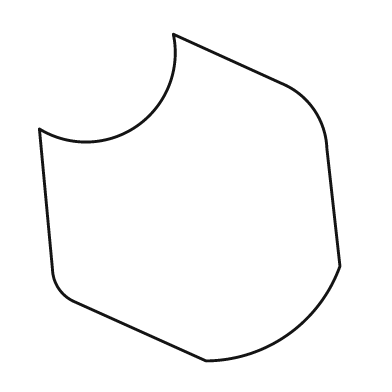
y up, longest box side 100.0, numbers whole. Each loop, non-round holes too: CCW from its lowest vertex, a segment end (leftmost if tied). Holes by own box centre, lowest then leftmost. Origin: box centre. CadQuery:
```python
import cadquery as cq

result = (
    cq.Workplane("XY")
    .moveTo(5.0, -50.0)
    .threePointArc((30.0, -42.0), (46.0, -21.0))
    .lineTo(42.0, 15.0)
    .threePointArc((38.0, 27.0), (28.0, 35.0))
    .lineTo(-5.0, 50.0)
    .threePointArc((-16.0, 22.0), (-46.0, 21.0))
    .lineTo(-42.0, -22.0)
    .threePointArc((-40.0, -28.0), (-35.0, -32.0))
    .close()
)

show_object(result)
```